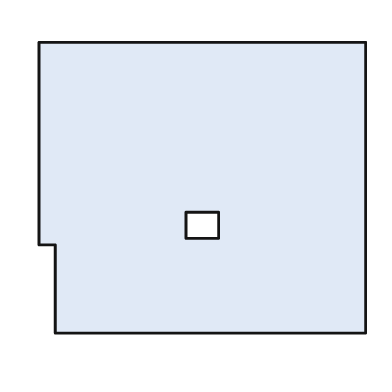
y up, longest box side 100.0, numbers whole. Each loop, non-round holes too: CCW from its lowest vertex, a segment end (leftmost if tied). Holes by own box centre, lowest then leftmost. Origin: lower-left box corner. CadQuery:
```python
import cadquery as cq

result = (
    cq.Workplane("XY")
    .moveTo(5.0, 0.0)
    .lineTo(100.0, 0.0)
    .lineTo(100.0, 89.0)
    .lineTo(0.0, 89.0)
    .lineTo(0.0, 27.0)
    .lineTo(5.0, 27.0)
    .close()
    .moveTo(45.0, 29.0)
    .lineTo(55.0, 29.0)
    .lineTo(55.0, 37.0)
    .lineTo(45.0, 37.0)
    .close()
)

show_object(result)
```